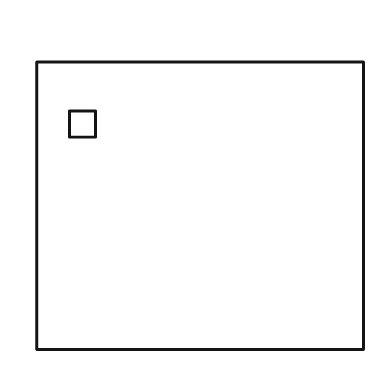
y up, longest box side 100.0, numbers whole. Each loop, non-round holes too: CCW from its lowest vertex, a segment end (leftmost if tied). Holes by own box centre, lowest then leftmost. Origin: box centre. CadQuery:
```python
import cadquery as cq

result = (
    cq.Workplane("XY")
    .moveTo(-50.0, -44.0)
    .lineTo(50.0, -44.0)
    .lineTo(50.0, 44.0)
    .lineTo(-50.0, 44.0)
    .close()
    .moveTo(-40.0, 21.0)
    .lineTo(-32.0, 21.0)
    .lineTo(-32.0, 29.0)
    .lineTo(-40.0, 29.0)
    .close()
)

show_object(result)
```